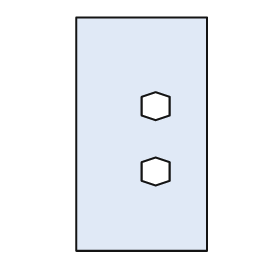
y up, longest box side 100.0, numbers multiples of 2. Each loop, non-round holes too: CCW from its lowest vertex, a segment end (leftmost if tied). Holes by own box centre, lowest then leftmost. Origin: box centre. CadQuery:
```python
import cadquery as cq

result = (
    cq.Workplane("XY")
    .moveTo(-28.0, -50.0)
    .lineTo(28.0, -50.0)
    .lineTo(28.0, 50.0)
    .lineTo(-28.0, 50.0)
    .close()
    .moveTo(6.0, -22.0)
    .lineTo(12.0, -20.0)
    .lineTo(12.0, -12.0)
    .lineTo(6.0, -10.0)
    .lineTo(0.0, -12.0)
    .lineTo(0.0, -20.0)
    .close()
    .moveTo(6.0, 6.0)
    .lineTo(12.0, 8.0)
    .lineTo(12.0, 16.0)
    .lineTo(6.0, 18.0)
    .lineTo(0.0, 16.0)
    .lineTo(0.0, 8.0)
    .close()
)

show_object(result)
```